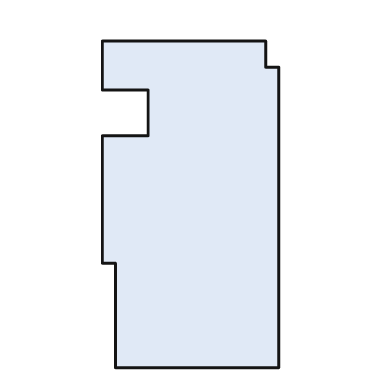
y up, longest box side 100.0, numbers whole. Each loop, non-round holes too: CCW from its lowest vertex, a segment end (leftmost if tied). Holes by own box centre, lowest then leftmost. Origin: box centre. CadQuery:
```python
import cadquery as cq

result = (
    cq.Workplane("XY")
    .moveTo(-23.0, -50.0)
    .lineTo(27.0, -50.0)
    .lineTo(27.0, 42.0)
    .lineTo(23.0, 42.0)
    .lineTo(23.0, 50.0)
    .lineTo(-27.0, 50.0)
    .lineTo(-27.0, 35.0)
    .lineTo(-13.0, 35.0)
    .lineTo(-13.0, 21.0)
    .lineTo(-27.0, 21.0)
    .lineTo(-27.0, -18.0)
    .lineTo(-23.0, -18.0)
    .close()
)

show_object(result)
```